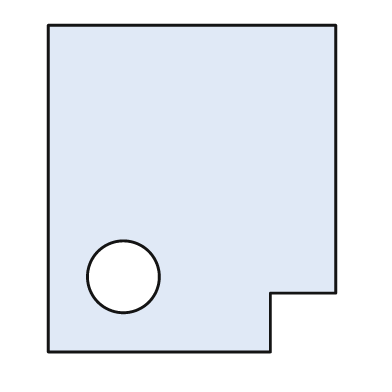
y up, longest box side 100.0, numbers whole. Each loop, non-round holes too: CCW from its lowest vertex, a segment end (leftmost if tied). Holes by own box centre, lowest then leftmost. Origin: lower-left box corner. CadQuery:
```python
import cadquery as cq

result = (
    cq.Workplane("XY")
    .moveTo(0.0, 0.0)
    .lineTo(68.0, 0.0)
    .lineTo(68.0, 18.0)
    .lineTo(88.0, 18.0)
    .lineTo(88.0, 100.0)
    .lineTo(0.0, 100.0)
    .close()
    .moveTo(23.0, 23.0)
    .circle(11.0)
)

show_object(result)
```